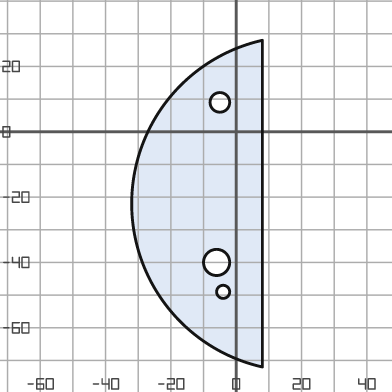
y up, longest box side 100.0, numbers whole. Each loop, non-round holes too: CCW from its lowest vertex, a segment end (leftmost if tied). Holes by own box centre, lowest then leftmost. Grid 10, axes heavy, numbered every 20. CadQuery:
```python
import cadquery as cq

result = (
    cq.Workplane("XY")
    .moveTo(8.0, -72.0)
    .lineTo(8.0, 28.0)
    .threePointArc((-32.0, -22.0), (8.0, -72.0))
    .close()
    .moveTo(-4.0, -49.0)
    .circle(2.0)
    .moveTo(-6.0, -40.0)
    .circle(4.0)
    .moveTo(-5.0, 9.0)
    .circle(3.0)
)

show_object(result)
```